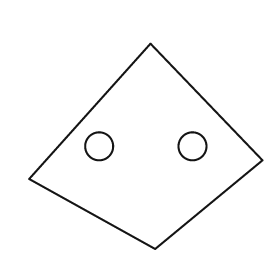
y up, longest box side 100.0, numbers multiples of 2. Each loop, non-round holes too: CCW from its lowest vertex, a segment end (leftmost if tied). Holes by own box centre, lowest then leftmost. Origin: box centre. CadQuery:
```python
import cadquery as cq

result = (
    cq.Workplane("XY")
    .moveTo(4.0, -44.0)
    .lineTo(50.0, -6.0)
    .lineTo(2.0, 44.0)
    .lineTo(-50.0, -14.0)
    .close()
    .moveTo(-20.0, 0.0)
    .circle(6.0)
    .moveTo(20.0, 0.0)
    .circle(6.0)
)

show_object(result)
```